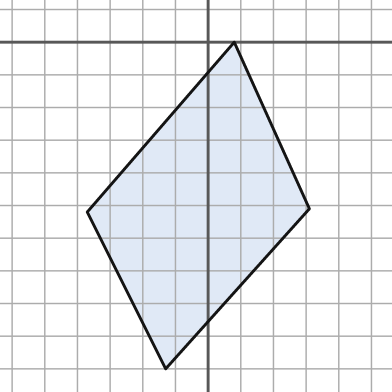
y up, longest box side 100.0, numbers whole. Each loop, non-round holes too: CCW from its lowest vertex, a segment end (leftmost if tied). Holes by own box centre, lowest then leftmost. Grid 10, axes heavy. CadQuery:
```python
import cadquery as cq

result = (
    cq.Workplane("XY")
    .moveTo(-13.0, -100.0)
    .lineTo(31.0, -51.0)
    .lineTo(8.0, 0.0)
    .lineTo(-37.0, -52.0)
    .close()
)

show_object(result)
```